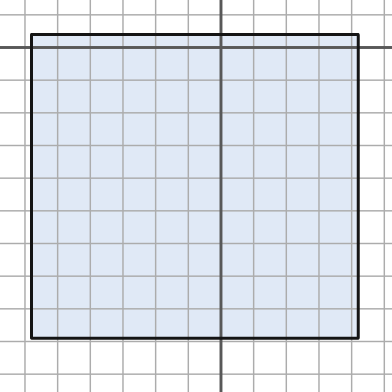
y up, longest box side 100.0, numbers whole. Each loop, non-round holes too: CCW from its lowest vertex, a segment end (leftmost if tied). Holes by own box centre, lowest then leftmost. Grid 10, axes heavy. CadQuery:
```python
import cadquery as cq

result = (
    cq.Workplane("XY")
    .moveTo(-58.0, -89.0)
    .lineTo(42.0, -89.0)
    .lineTo(42.0, 4.0)
    .lineTo(-58.0, 4.0)
    .close()
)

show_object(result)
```